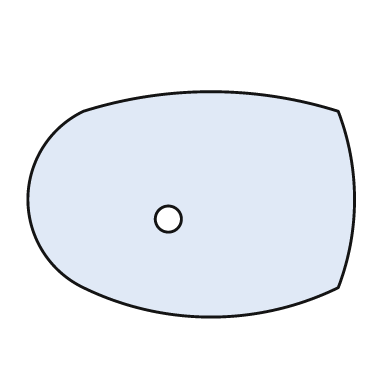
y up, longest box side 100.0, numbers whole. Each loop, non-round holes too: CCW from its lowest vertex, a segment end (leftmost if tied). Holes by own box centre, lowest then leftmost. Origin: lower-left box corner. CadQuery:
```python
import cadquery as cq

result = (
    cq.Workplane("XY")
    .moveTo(17.0, 9.0)
    .threePointArc((56.0, 0.0), (95.0, 9.0))
    .threePointArc((100.0, 36.0), (95.0, 63.0))
    .threePointArc((56.0, 69.0), (17.0, 63.0))
    .threePointArc((0.0, 36.0), (17.0, 9.0))
    .close()
    .moveTo(43.0, 30.0)
    .circle(4.0)
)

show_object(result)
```